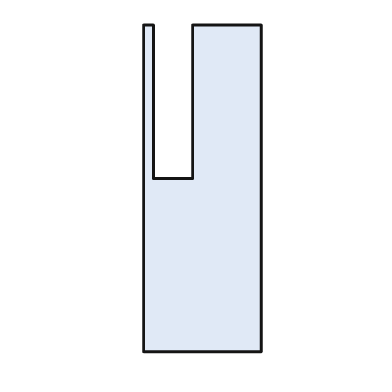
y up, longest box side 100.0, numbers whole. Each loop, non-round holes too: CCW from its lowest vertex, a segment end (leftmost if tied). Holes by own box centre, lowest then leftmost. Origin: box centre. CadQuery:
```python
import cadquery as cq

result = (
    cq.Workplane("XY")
    .moveTo(-18.0, -50.0)
    .lineTo(18.0, -50.0)
    .lineTo(18.0, 50.0)
    .lineTo(-3.0, 50.0)
    .lineTo(-3.0, 3.0)
    .lineTo(-15.0, 3.0)
    .lineTo(-15.0, 50.0)
    .lineTo(-18.0, 50.0)
    .close()
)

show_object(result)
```